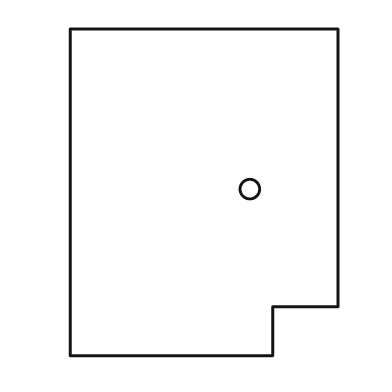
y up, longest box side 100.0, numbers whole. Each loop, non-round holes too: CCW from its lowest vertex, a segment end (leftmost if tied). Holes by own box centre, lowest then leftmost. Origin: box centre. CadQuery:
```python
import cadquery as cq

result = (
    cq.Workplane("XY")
    .moveTo(-41.0, -50.0)
    .lineTo(21.0, -50.0)
    .lineTo(21.0, -35.0)
    .lineTo(41.0, -35.0)
    .lineTo(41.0, 50.0)
    .lineTo(-41.0, 50.0)
    .close()
    .moveTo(14.0, 1.0)
    .circle(3.0)
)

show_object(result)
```